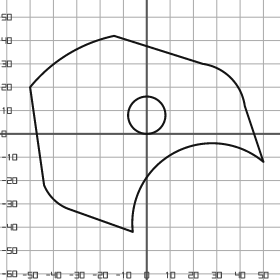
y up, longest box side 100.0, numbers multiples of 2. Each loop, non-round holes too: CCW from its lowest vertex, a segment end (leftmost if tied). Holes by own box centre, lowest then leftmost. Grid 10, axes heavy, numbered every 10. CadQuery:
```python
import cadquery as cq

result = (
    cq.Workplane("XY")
    .moveTo(-6.0, -42.0)
    .threePointArc((12.0, -8.0), (50.0, -12.0))
    .lineTo(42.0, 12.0)
    .threePointArc((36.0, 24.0), (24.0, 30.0))
    .lineTo(-14.0, 42.0)
    .threePointArc((-34.0, 34.0), (-50.0, 20.0))
    .lineTo(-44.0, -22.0)
    .threePointArc((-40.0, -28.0), (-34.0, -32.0))
    .close()
    .moveTo(0.0, 8.0)
    .circle(8.0)
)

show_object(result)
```